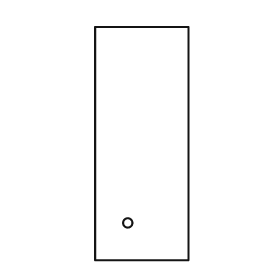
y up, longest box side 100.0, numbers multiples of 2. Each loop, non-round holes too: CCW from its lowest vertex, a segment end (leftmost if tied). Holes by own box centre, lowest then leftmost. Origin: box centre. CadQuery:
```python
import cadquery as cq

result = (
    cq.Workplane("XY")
    .moveTo(-20.0, -50.0)
    .lineTo(20.0, -50.0)
    .lineTo(20.0, 50.0)
    .lineTo(-20.0, 50.0)
    .close()
    .moveTo(-6.0, -34.0)
    .circle(2.0)
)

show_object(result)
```